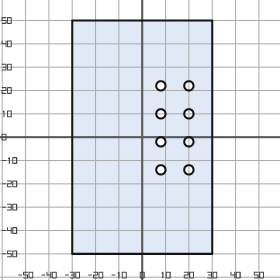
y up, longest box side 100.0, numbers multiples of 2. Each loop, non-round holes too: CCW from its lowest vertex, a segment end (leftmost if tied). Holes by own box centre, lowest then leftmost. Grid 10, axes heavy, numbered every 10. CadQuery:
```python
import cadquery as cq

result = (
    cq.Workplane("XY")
    .moveTo(-30.0, -50.0)
    .lineTo(30.0, -50.0)
    .lineTo(30.0, 50.0)
    .lineTo(-30.0, 50.0)
    .close()
    .moveTo(8.0, -14.0)
    .circle(2.0)
    .moveTo(20.0, -14.0)
    .circle(2.0)
    .moveTo(8.0, -2.0)
    .circle(2.0)
    .moveTo(20.0, -2.0)
    .circle(2.0)
    .moveTo(8.0, 10.0)
    .circle(2.0)
    .moveTo(20.0, 10.0)
    .circle(2.0)
    .moveTo(8.0, 22.0)
    .circle(2.0)
    .moveTo(20.0, 22.0)
    .circle(2.0)
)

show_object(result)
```